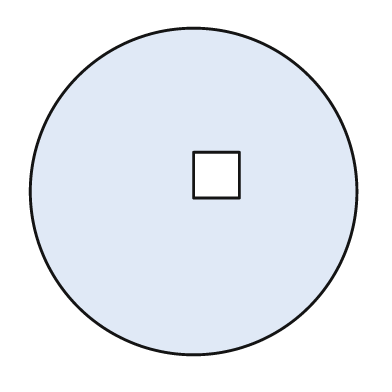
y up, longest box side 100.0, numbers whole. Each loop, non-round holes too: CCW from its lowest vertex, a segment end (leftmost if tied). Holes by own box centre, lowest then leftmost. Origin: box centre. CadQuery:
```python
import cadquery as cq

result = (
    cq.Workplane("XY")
    .moveTo(0.0, 0.0)
    .circle(50.0)
    .moveTo(0.0, -2.0)
    .lineTo(14.0, -2.0)
    .lineTo(14.0, 12.0)
    .lineTo(0.0, 12.0)
    .close()
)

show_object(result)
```